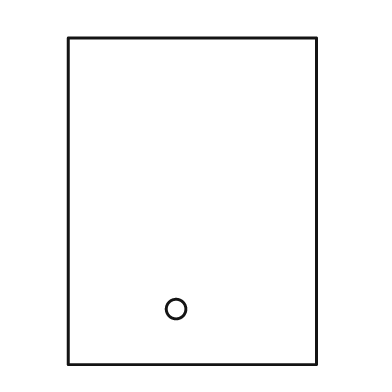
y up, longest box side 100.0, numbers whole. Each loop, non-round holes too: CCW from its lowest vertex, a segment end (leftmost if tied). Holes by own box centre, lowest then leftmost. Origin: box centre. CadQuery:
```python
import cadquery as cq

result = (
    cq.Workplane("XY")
    .moveTo(-38.0, -50.0)
    .lineTo(38.0, -50.0)
    .lineTo(38.0, 50.0)
    .lineTo(-38.0, 50.0)
    .close()
    .moveTo(-5.0, -33.0)
    .circle(3.0)
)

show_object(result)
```